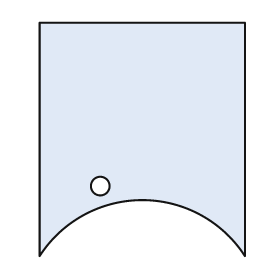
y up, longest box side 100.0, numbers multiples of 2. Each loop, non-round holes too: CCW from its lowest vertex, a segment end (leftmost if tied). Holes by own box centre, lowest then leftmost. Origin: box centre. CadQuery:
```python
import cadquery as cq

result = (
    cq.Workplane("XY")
    .moveTo(-44.0, -50.0)
    .threePointArc((0.0, -26.0), (44.0, -50.0))
    .lineTo(44.0, 50.0)
    .lineTo(-44.0, 50.0)
    .close()
    .moveTo(-18.0, -20.0)
    .circle(4.0)
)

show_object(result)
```